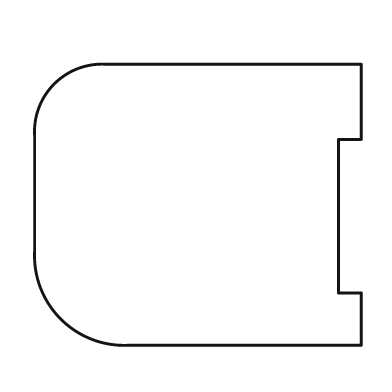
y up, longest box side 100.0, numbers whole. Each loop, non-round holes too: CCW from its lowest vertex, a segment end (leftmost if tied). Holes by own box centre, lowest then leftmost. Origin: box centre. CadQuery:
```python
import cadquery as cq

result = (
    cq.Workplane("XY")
    .moveTo(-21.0, -43.0)
    .lineTo(50.0, -43.0)
    .lineTo(50.0, -27.0)
    .lineTo(43.0, -27.0)
    .lineTo(43.0, 20.0)
    .lineTo(50.0, 20.0)
    .lineTo(50.0, 43.0)
    .lineTo(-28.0, 43.0)
    .threePointArc((-44.0, 37.0), (-50.0, 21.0))
    .lineTo(-50.0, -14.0)
    .threePointArc((-42.0, -35.0), (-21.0, -43.0))
    .close()
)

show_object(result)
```